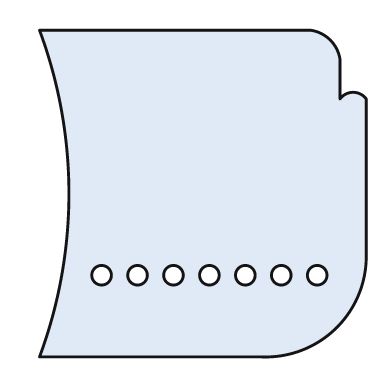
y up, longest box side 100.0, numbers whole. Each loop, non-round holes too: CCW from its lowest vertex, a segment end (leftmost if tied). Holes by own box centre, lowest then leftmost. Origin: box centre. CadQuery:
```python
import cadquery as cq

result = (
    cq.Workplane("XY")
    .moveTo(-50.0, -50.0)
    .lineTo(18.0, -50.0)
    .threePointArc((41.0, -41.0), (50.0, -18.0))
    .lineTo(50.0, 29.0)
    .threePointArc((46.0, 31.0), (42.0, 29.0))
    .lineTo(42.0, 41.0)
    .threePointArc((39.0, 47.0), (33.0, 50.0))
    .lineTo(-50.0, 50.0)
    .threePointArc((-41.0, 0.0), (-50.0, -50.0))
    .close()
    .moveTo(-31.0, -25.0)
    .circle(3.0)
    .moveTo(-20.0, -25.0)
    .circle(3.0)
    .moveTo(-9.0, -25.0)
    .circle(3.0)
    .moveTo(2.0, -25.0)
    .circle(3.0)
    .moveTo(13.0, -25.0)
    .circle(3.0)
    .moveTo(24.0, -25.0)
    .circle(3.0)
    .moveTo(35.0, -25.0)
    .circle(3.0)
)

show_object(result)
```